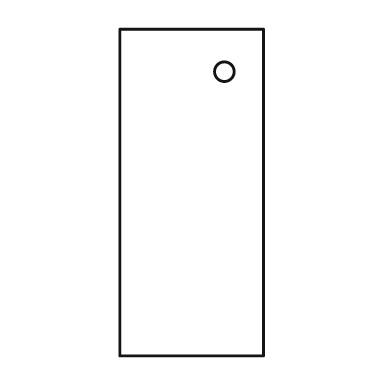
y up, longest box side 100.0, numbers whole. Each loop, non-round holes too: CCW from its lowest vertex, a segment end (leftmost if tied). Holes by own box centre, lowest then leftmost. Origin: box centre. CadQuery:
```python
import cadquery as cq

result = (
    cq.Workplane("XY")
    .moveTo(-22.0, -50.0)
    .lineTo(22.0, -50.0)
    .lineTo(22.0, 50.0)
    .lineTo(-22.0, 50.0)
    .close()
    .moveTo(10.0, 37.0)
    .circle(3.0)
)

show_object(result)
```